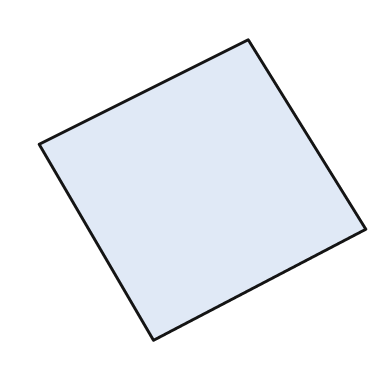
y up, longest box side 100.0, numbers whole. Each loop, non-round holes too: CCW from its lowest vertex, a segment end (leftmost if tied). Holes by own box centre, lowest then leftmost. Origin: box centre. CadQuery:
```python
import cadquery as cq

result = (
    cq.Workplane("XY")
    .moveTo(-15.0, -46.0)
    .lineTo(50.0, -12.0)
    .lineTo(14.0, 46.0)
    .lineTo(-50.0, 14.0)
    .close()
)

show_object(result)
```